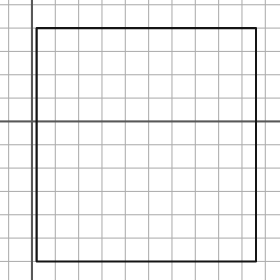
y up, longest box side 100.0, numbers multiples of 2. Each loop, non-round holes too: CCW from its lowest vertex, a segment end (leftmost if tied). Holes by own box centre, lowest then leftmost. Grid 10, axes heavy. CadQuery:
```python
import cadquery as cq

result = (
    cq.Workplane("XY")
    .moveTo(2.0, -60.0)
    .lineTo(96.0, -60.0)
    .lineTo(96.0, 40.0)
    .lineTo(2.0, 40.0)
    .close()
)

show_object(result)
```